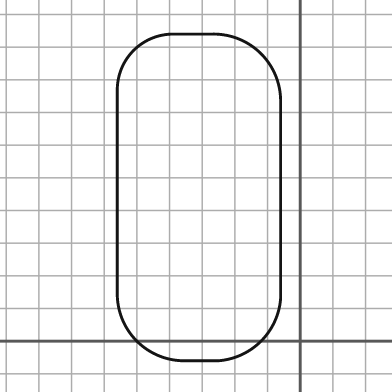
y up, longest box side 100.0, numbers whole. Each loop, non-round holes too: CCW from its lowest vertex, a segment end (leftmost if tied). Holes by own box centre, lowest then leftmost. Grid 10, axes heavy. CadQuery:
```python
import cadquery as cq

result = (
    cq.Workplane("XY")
    .moveTo(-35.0, -6.0)
    .lineTo(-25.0, -6.0)
    .threePointArc((-12.0, 0.0), (-6.0, 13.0))
    .lineTo(-6.0, 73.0)
    .threePointArc((-12.0, 88.0), (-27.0, 94.0))
    .lineTo(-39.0, 94.0)
    .threePointArc((-51.0, 89.0), (-56.0, 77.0))
    .lineTo(-56.0, 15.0)
    .threePointArc((-50.0, 0.0), (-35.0, -6.0))
    .close()
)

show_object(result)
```